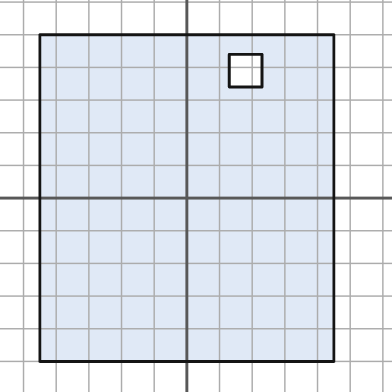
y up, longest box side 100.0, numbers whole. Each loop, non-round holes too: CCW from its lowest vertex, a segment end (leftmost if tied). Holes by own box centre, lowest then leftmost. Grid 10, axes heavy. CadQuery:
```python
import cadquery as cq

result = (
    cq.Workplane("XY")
    .moveTo(-45.0, -50.0)
    .lineTo(45.0, -50.0)
    .lineTo(45.0, 50.0)
    .lineTo(-45.0, 50.0)
    .close()
    .moveTo(13.0, 34.0)
    .lineTo(23.0, 34.0)
    .lineTo(23.0, 44.0)
    .lineTo(13.0, 44.0)
    .close()
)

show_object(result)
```